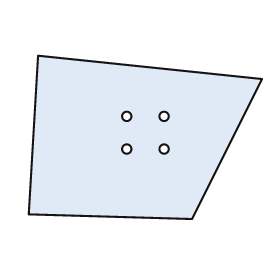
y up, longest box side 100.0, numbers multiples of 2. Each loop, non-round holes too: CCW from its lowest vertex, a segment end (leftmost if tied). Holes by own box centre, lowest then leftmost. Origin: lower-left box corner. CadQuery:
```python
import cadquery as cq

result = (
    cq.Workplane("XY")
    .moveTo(70.0, 0.0)
    .lineTo(100.0, 60.0)
    .lineTo(4.0, 70.0)
    .lineTo(0.0, 2.0)
    .close()
    .moveTo(42.0, 30.0)
    .circle(2.0)
    .moveTo(58.0, 30.0)
    .circle(2.0)
    .moveTo(42.0, 44.0)
    .circle(2.0)
    .moveTo(58.0, 44.0)
    .circle(2.0)
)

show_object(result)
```